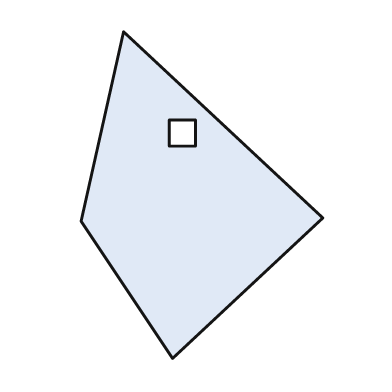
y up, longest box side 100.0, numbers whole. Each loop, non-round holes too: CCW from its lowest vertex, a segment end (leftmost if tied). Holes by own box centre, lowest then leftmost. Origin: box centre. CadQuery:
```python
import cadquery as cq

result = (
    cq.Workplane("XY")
    .moveTo(-9.0, -50.0)
    .lineTo(37.0, -7.0)
    .lineTo(-24.0, 50.0)
    .lineTo(-37.0, -8.0)
    .close()
    .moveTo(-10.0, 15.0)
    .lineTo(-2.0, 15.0)
    .lineTo(-2.0, 23.0)
    .lineTo(-10.0, 23.0)
    .close()
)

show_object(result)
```